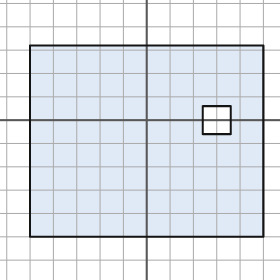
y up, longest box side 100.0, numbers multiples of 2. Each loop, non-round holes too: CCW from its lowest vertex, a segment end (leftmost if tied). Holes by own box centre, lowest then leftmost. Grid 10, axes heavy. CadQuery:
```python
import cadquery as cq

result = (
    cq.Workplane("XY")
    .moveTo(-50.0, -50.0)
    .lineTo(50.0, -50.0)
    .lineTo(50.0, 32.0)
    .lineTo(-50.0, 32.0)
    .close()
    .moveTo(24.0, -6.0)
    .lineTo(36.0, -6.0)
    .lineTo(36.0, 6.0)
    .lineTo(24.0, 6.0)
    .close()
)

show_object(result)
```